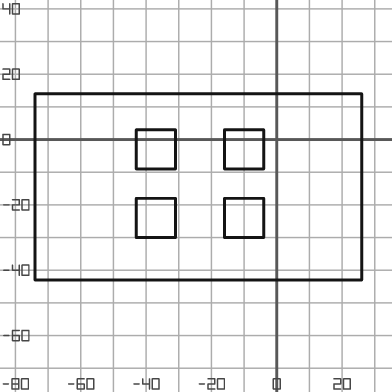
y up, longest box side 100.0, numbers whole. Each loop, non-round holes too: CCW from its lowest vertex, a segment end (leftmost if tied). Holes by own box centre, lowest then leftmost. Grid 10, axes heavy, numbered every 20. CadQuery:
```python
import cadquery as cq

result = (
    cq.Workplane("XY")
    .moveTo(-74.0, -43.0)
    .lineTo(26.0, -43.0)
    .lineTo(26.0, 14.0)
    .lineTo(-74.0, 14.0)
    .close()
    .moveTo(-43.0, -30.0)
    .lineTo(-31.0, -30.0)
    .lineTo(-31.0, -18.0)
    .lineTo(-43.0, -18.0)
    .close()
    .moveTo(-16.0, -30.0)
    .lineTo(-4.0, -30.0)
    .lineTo(-4.0, -18.0)
    .lineTo(-16.0, -18.0)
    .close()
    .moveTo(-43.0, -9.0)
    .lineTo(-31.0, -9.0)
    .lineTo(-31.0, 3.0)
    .lineTo(-43.0, 3.0)
    .close()
    .moveTo(-16.0, -9.0)
    .lineTo(-4.0, -9.0)
    .lineTo(-4.0, 3.0)
    .lineTo(-16.0, 3.0)
    .close()
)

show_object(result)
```